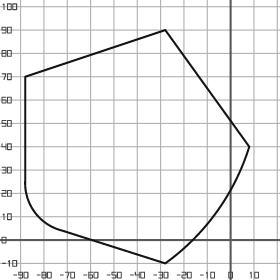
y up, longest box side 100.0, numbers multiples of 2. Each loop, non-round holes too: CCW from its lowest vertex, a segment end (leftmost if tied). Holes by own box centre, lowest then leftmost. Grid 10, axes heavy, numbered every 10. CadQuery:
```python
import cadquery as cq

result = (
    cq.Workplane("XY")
    .moveTo(-28.0, -10.0)
    .threePointArc((-6.0, 12.0), (8.0, 40.0))
    .lineTo(-28.0, 90.0)
    .lineTo(-88.0, 70.0)
    .lineTo(-88.0, 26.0)
    .threePointArc((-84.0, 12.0), (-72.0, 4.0))
    .close()
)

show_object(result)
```